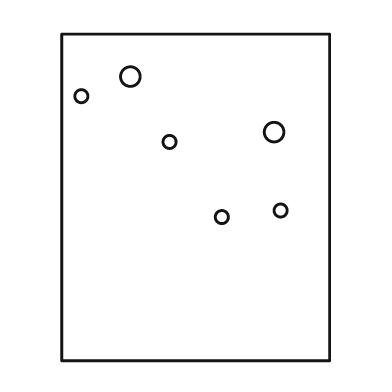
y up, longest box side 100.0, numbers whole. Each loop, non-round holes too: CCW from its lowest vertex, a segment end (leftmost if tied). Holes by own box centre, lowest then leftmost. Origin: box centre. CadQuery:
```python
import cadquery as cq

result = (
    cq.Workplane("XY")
    .moveTo(-41.0, -50.0)
    .lineTo(41.0, -50.0)
    .lineTo(41.0, 50.0)
    .lineTo(-41.0, 50.0)
    .close()
    .moveTo(8.0, -6.0)
    .circle(2.0)
    .moveTo(26.0, -4.0)
    .circle(2.0)
    .moveTo(-8.0, 17.0)
    .circle(2.0)
    .moveTo(24.0, 20.0)
    .circle(3.0)
    .moveTo(-35.0, 31.0)
    .circle(2.0)
    .moveTo(-20.0, 37.0)
    .circle(3.0)
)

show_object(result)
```